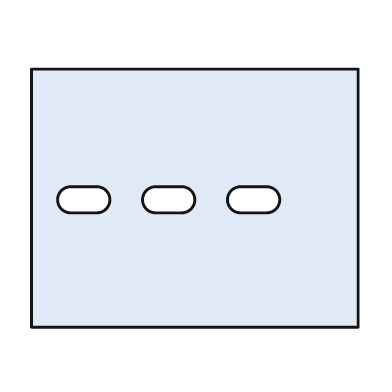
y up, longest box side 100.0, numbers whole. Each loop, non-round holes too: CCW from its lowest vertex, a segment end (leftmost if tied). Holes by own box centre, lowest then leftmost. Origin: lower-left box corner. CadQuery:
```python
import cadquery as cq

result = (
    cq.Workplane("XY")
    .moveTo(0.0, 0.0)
    .lineTo(100.0, 0.0)
    .lineTo(100.0, 79.0)
    .lineTo(0.0, 79.0)
    .close()
    .moveTo(12.0, 35.0)
    .lineTo(20.0, 35.0)
    .threePointArc((24.0, 39.0), (20.0, 43.0))
    .lineTo(12.0, 43.0)
    .threePointArc((8.0, 39.0), (12.0, 35.0))
    .close()
    .moveTo(38.0, 35.0)
    .lineTo(46.0, 35.0)
    .threePointArc((50.0, 39.0), (46.0, 43.0))
    .lineTo(38.0, 43.0)
    .threePointArc((34.0, 39.0), (38.0, 35.0))
    .close()
    .moveTo(64.0, 35.0)
    .lineTo(72.0, 35.0)
    .threePointArc((76.0, 39.0), (72.0, 43.0))
    .lineTo(64.0, 43.0)
    .threePointArc((60.0, 39.0), (64.0, 35.0))
    .close()
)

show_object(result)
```